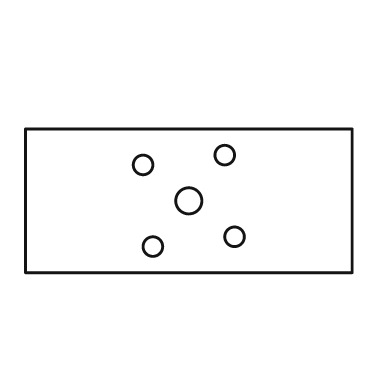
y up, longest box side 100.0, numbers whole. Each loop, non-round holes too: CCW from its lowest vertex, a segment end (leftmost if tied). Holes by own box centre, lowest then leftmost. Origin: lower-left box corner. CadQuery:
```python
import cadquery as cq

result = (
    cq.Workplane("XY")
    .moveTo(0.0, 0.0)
    .lineTo(100.0, 0.0)
    .lineTo(100.0, 44.0)
    .lineTo(0.0, 44.0)
    .close()
    .moveTo(39.0, 8.0)
    .circle(3.0)
    .moveTo(64.0, 11.0)
    .circle(3.0)
    .moveTo(50.0, 22.0)
    .circle(4.0)
    .moveTo(36.0, 33.0)
    .circle(3.0)
    .moveTo(61.0, 36.0)
    .circle(3.0)
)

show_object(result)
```